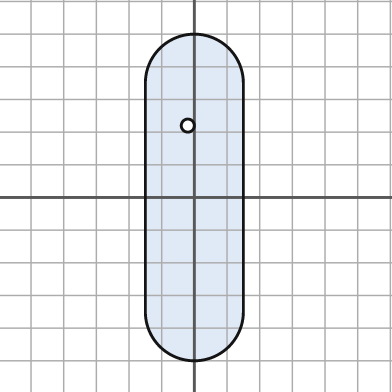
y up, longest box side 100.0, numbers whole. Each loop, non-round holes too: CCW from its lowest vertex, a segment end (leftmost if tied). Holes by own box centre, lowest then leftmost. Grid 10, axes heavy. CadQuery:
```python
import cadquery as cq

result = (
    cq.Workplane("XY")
    .moveTo(-15.0, -35.0)
    .threePointArc((0.0, -50.0), (15.0, -35.0))
    .lineTo(15.0, 35.0)
    .threePointArc((0.0, 50.0), (-15.0, 35.0))
    .close()
    .moveTo(-2.0, 22.0)
    .circle(2.0)
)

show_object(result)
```